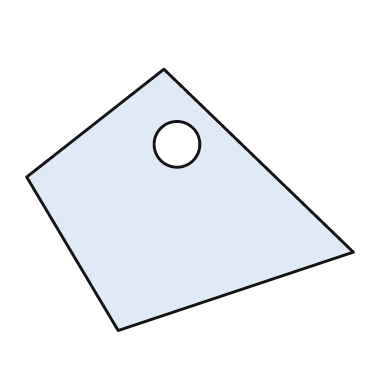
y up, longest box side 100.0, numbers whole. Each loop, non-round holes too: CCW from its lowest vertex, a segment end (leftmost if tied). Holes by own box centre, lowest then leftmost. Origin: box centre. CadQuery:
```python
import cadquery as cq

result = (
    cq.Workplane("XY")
    .moveTo(-22.0, -40.0)
    .lineTo(50.0, -16.0)
    .lineTo(-8.0, 40.0)
    .lineTo(-50.0, 7.0)
    .close()
    .moveTo(-4.0, 17.0)
    .circle(7.0)
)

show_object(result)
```